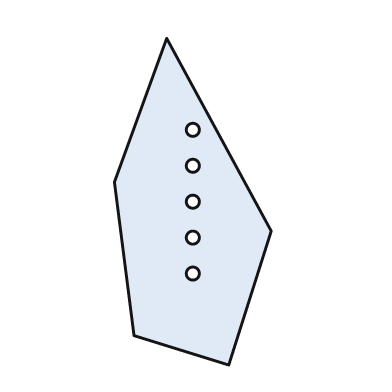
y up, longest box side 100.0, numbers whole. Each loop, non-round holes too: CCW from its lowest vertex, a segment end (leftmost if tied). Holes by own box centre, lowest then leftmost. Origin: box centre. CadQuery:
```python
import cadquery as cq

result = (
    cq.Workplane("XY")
    .moveTo(11.0, -50.0)
    .lineTo(24.0, -9.0)
    .lineTo(-8.0, 50.0)
    .lineTo(-24.0, 6.0)
    .lineTo(-18.0, -41.0)
    .close()
    .moveTo(0.0, -22.0)
    .circle(2.0)
    .moveTo(0.0, -11.0)
    .circle(2.0)
    .moveTo(0.0, 0.0)
    .circle(2.0)
    .moveTo(0.0, 11.0)
    .circle(2.0)
    .moveTo(0.0, 22.0)
    .circle(2.0)
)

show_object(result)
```